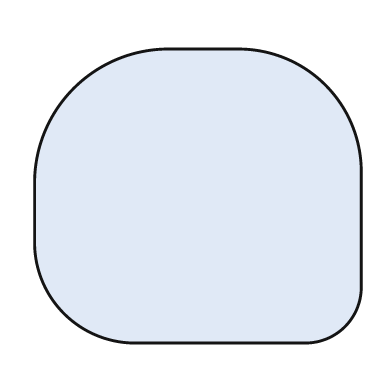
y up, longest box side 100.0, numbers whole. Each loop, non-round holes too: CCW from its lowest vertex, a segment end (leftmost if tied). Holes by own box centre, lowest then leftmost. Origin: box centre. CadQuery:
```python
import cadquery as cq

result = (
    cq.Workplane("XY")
    .moveTo(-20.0, -45.0)
    .lineTo(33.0, -45.0)
    .threePointArc((45.0, -40.0), (50.0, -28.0))
    .lineTo(50.0, 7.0)
    .threePointArc((39.0, 34.0), (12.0, 45.0))
    .lineTo(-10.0, 45.0)
    .threePointArc((-38.0, 33.0), (-50.0, 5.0))
    .lineTo(-50.0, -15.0)
    .threePointArc((-41.0, -36.0), (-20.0, -45.0))
    .close()
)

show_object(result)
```